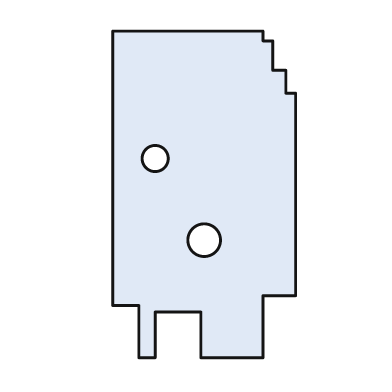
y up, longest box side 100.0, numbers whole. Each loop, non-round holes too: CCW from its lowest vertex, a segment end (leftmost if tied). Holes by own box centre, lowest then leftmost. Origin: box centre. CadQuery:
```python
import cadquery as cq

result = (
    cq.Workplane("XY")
    .moveTo(-20.0, -50.0)
    .lineTo(-15.0, -50.0)
    .lineTo(-15.0, -36.0)
    .lineTo(-1.0, -36.0)
    .lineTo(-1.0, -50.0)
    .lineTo(18.0, -50.0)
    .lineTo(18.0, -31.0)
    .lineTo(28.0, -31.0)
    .lineTo(28.0, 31.0)
    .lineTo(25.0, 31.0)
    .lineTo(25.0, 38.0)
    .lineTo(21.0, 38.0)
    .lineTo(21.0, 47.0)
    .lineTo(18.0, 47.0)
    .lineTo(18.0, 50.0)
    .lineTo(-28.0, 50.0)
    .lineTo(-28.0, -34.0)
    .lineTo(-20.0, -34.0)
    .close()
    .moveTo(0.0, -14.0)
    .circle(5.0)
    .moveTo(-15.0, 11.0)
    .circle(4.0)
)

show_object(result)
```